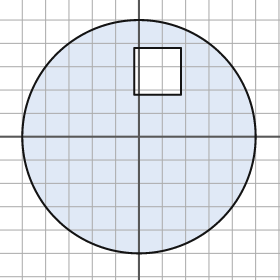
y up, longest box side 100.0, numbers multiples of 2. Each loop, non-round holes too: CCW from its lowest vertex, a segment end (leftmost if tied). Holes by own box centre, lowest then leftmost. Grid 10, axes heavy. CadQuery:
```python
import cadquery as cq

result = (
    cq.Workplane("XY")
    .moveTo(0.0, 0.0)
    .circle(50.0)
    .moveTo(-2.0, 18.0)
    .lineTo(18.0, 18.0)
    .lineTo(18.0, 38.0)
    .lineTo(-2.0, 38.0)
    .close()
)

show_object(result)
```